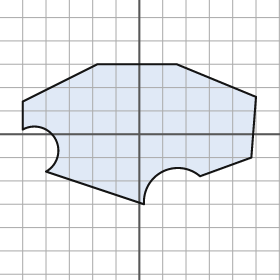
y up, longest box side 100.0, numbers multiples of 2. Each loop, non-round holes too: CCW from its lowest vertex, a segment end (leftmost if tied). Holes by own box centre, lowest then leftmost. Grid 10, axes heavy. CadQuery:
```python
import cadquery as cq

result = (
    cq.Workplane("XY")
    .moveTo(2.0, -30.0)
    .threePointArc((10.0, -16.0), (26.0, -18.0))
    .lineTo(48.0, -10.0)
    .lineTo(50.0, 16.0)
    .lineTo(16.0, 30.0)
    .lineTo(-18.0, 30.0)
    .lineTo(-50.0, 14.0)
    .lineTo(-50.0, 2.0)
    .threePointArc((-36.0, -2.0), (-40.0, -16.0))
    .close()
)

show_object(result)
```